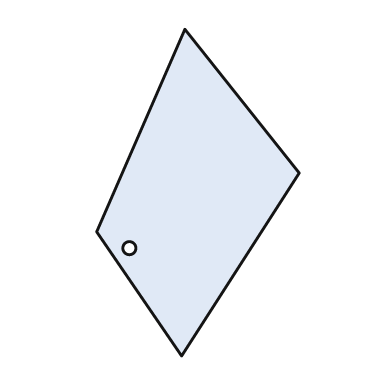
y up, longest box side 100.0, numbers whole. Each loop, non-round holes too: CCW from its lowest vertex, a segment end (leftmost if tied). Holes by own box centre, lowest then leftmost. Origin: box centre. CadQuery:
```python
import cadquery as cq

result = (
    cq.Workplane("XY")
    .moveTo(-5.0, -50.0)
    .lineTo(31.0, 6.0)
    .lineTo(-4.0, 50.0)
    .lineTo(-31.0, -12.0)
    .close()
    .moveTo(-21.0, -17.0)
    .circle(2.0)
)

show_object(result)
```